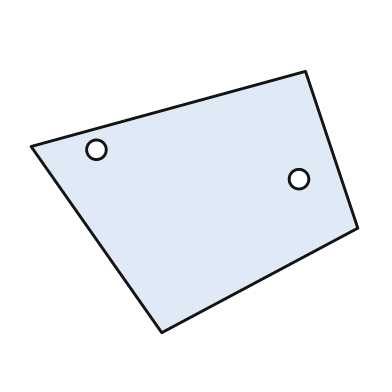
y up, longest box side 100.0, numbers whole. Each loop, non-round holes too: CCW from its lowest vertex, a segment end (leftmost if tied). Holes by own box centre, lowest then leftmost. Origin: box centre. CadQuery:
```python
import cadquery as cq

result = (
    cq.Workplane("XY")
    .moveTo(-10.0, -40.0)
    .lineTo(50.0, -8.0)
    .lineTo(34.0, 40.0)
    .lineTo(-50.0, 17.0)
    .close()
    .moveTo(32.0, 7.0)
    .circle(3.0)
    .moveTo(-30.0, 16.0)
    .circle(3.0)
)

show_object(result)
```